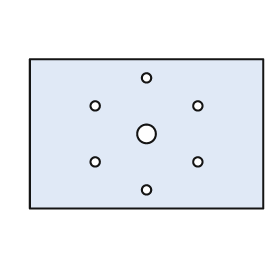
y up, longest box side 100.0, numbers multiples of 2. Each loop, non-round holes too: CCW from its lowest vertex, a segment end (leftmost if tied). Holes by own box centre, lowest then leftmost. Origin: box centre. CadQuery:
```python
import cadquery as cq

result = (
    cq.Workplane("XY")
    .moveTo(-50.0, -32.0)
    .lineTo(50.0, -32.0)
    .lineTo(50.0, 32.0)
    .lineTo(-50.0, 32.0)
    .close()
    .moveTo(0.0, -24.0)
    .circle(2.0)
    .moveTo(-22.0, -12.0)
    .circle(2.0)
    .moveTo(22.0, -12.0)
    .circle(2.0)
    .moveTo(0.0, 0.0)
    .circle(4.0)
    .moveTo(-22.0, 12.0)
    .circle(2.0)
    .moveTo(22.0, 12.0)
    .circle(2.0)
    .moveTo(0.0, 24.0)
    .circle(2.0)
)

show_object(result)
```